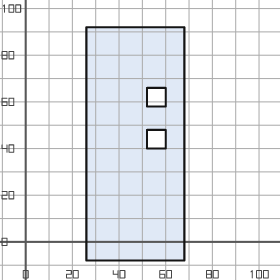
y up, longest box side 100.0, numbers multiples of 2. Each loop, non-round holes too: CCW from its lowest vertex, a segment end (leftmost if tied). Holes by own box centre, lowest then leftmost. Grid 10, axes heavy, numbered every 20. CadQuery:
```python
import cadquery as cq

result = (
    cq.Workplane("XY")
    .moveTo(26.0, -8.0)
    .lineTo(68.0, -8.0)
    .lineTo(68.0, 92.0)
    .lineTo(26.0, 92.0)
    .close()
    .moveTo(52.0, 40.0)
    .lineTo(60.0, 40.0)
    .lineTo(60.0, 48.0)
    .lineTo(52.0, 48.0)
    .close()
    .moveTo(52.0, 58.0)
    .lineTo(60.0, 58.0)
    .lineTo(60.0, 66.0)
    .lineTo(52.0, 66.0)
    .close()
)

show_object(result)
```